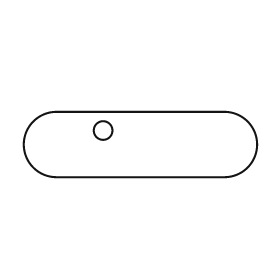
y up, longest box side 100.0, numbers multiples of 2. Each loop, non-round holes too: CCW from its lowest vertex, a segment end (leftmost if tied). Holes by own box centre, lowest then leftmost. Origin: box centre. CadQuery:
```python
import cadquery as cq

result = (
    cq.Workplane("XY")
    .moveTo(-36.0, -14.0)
    .lineTo(36.0, -14.0)
    .threePointArc((50.0, 0.0), (36.0, 14.0))
    .lineTo(-36.0, 14.0)
    .threePointArc((-50.0, 0.0), (-36.0, -14.0))
    .close()
    .moveTo(-16.0, 6.0)
    .circle(4.0)
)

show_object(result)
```